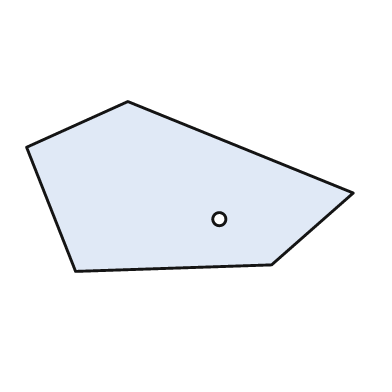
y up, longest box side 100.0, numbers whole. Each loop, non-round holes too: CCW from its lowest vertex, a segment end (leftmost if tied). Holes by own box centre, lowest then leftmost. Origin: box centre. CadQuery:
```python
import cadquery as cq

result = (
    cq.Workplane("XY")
    .moveTo(-35.0, -26.0)
    .lineTo(25.0, -24.0)
    .lineTo(50.0, -2.0)
    .lineTo(-19.0, 26.0)
    .lineTo(-50.0, 12.0)
    .close()
    .moveTo(9.0, -10.0)
    .circle(2.0)
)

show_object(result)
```